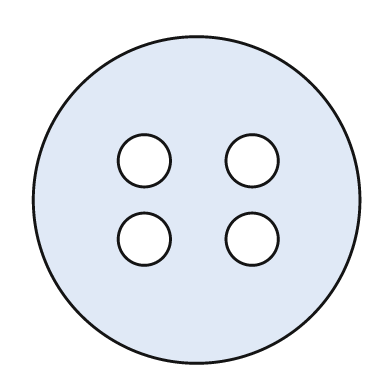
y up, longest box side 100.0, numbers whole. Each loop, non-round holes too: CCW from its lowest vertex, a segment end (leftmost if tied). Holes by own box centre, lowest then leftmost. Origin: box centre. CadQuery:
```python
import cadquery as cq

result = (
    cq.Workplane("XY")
    .moveTo(0.0, 0.0)
    .circle(50.0)
    .moveTo(-16.0, -12.0)
    .circle(8.0)
    .moveTo(17.0, -12.0)
    .circle(8.0)
    .moveTo(-16.0, 12.0)
    .circle(8.0)
    .moveTo(17.0, 12.0)
    .circle(8.0)
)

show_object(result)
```